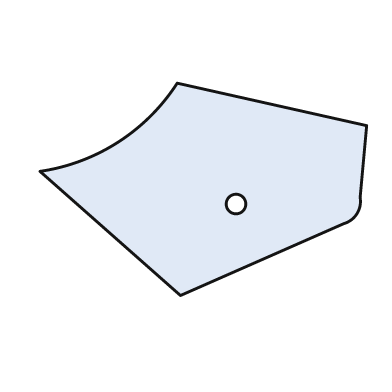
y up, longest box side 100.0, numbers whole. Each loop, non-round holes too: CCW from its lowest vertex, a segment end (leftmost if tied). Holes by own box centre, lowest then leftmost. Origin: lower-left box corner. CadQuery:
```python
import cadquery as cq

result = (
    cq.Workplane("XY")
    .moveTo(43.0, 0.0)
    .lineTo(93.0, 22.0)
    .threePointArc((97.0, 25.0), (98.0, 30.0))
    .lineTo(100.0, 52.0)
    .lineTo(42.0, 65.0)
    .threePointArc((24.0, 47.0), (0.0, 38.0))
    .close()
    .moveTo(60.0, 28.0)
    .circle(3.0)
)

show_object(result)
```